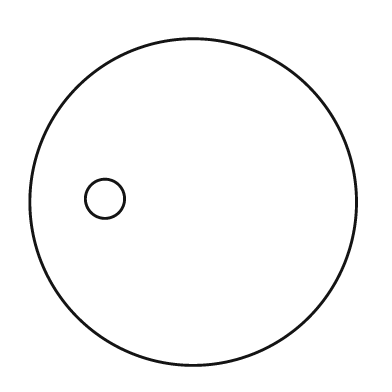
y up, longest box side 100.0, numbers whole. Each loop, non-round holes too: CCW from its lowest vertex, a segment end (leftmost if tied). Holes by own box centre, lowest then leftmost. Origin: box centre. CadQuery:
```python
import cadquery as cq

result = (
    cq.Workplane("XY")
    .moveTo(0.0, 0.0)
    .circle(50.0)
    .moveTo(-27.0, 1.0)
    .circle(6.0)
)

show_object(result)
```